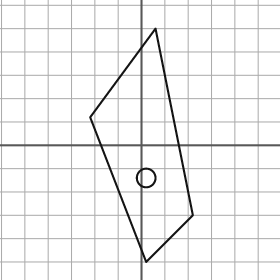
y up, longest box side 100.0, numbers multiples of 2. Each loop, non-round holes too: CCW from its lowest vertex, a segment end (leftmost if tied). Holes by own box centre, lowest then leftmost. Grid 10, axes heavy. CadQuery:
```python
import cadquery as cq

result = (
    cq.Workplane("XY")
    .moveTo(2.0, -50.0)
    .lineTo(22.0, -30.0)
    .lineTo(6.0, 50.0)
    .lineTo(-22.0, 12.0)
    .close()
    .moveTo(2.0, -14.0)
    .circle(4.0)
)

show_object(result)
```